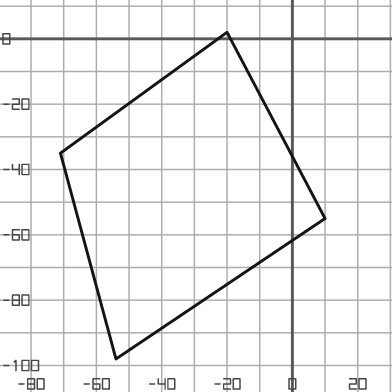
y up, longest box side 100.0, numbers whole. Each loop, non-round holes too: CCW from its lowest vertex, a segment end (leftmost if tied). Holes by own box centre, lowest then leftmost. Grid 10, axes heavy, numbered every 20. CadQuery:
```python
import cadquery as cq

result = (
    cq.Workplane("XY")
    .moveTo(-54.0, -98.0)
    .lineTo(10.0, -55.0)
    .lineTo(-20.0, 2.0)
    .lineTo(-71.0, -35.0)
    .close()
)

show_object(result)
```